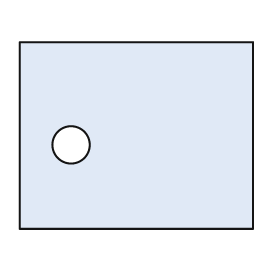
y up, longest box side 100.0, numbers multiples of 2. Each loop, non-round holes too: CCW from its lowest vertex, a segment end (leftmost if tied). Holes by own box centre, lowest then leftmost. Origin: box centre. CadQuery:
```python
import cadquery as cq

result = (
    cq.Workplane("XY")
    .moveTo(-50.0, -40.0)
    .lineTo(50.0, -40.0)
    .lineTo(50.0, 40.0)
    .lineTo(-50.0, 40.0)
    .close()
    .moveTo(-28.0, -4.0)
    .circle(8.0)
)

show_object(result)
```